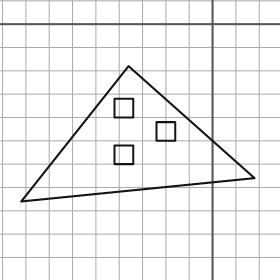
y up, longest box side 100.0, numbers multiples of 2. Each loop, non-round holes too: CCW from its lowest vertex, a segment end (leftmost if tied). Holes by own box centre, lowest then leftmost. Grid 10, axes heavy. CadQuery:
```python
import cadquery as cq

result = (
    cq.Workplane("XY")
    .moveTo(-82.0, -76.0)
    .lineTo(18.0, -66.0)
    .lineTo(-36.0, -18.0)
    .close()
    .moveTo(-42.0, -60.0)
    .lineTo(-34.0, -60.0)
    .lineTo(-34.0, -52.0)
    .lineTo(-42.0, -52.0)
    .close()
    .moveTo(-24.0, -50.0)
    .lineTo(-16.0, -50.0)
    .lineTo(-16.0, -42.0)
    .lineTo(-24.0, -42.0)
    .close()
    .moveTo(-42.0, -40.0)
    .lineTo(-34.0, -40.0)
    .lineTo(-34.0, -32.0)
    .lineTo(-42.0, -32.0)
    .close()
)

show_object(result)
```